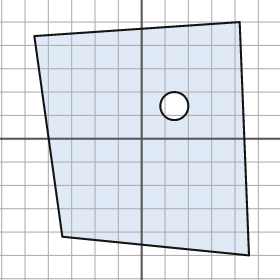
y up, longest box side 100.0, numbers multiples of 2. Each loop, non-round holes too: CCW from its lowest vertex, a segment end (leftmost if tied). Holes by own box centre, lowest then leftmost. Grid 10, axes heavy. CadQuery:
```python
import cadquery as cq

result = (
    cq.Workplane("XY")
    .moveTo(46.0, -50.0)
    .lineTo(42.0, 50.0)
    .lineTo(-46.0, 44.0)
    .lineTo(-34.0, -42.0)
    .close()
    .moveTo(14.0, 14.0)
    .circle(6.0)
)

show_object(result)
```